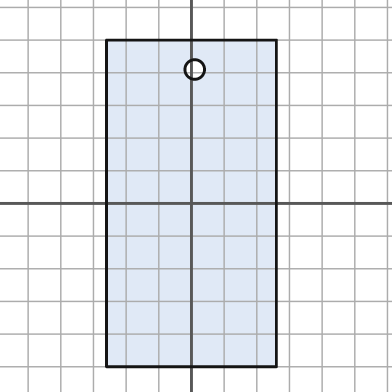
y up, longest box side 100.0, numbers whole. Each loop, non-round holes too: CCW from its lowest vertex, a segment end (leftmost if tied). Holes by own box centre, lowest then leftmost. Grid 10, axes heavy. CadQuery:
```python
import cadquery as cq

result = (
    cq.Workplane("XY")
    .moveTo(-26.0, -50.0)
    .lineTo(26.0, -50.0)
    .lineTo(26.0, 50.0)
    .lineTo(-26.0, 50.0)
    .close()
    .moveTo(1.0, 41.0)
    .circle(3.0)
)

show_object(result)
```